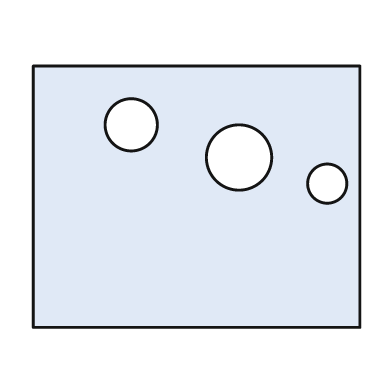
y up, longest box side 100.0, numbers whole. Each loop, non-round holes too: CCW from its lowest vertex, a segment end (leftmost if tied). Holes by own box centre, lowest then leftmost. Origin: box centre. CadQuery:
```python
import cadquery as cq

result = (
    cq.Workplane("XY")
    .moveTo(-50.0, -40.0)
    .lineTo(50.0, -40.0)
    .lineTo(50.0, 40.0)
    .lineTo(-50.0, 40.0)
    .close()
    .moveTo(40.0, 4.0)
    .circle(6.0)
    .moveTo(13.0, 12.0)
    .circle(10.0)
    .moveTo(-20.0, 22.0)
    .circle(8.0)
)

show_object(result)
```